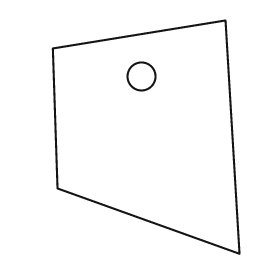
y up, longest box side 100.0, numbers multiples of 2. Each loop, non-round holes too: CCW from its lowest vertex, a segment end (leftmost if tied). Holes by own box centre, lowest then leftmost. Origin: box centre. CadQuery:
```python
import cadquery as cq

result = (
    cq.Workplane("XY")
    .moveTo(40.0, -50.0)
    .lineTo(34.0, 50.0)
    .lineTo(-40.0, 38.0)
    .lineTo(-38.0, -22.0)
    .close()
    .moveTo(-2.0, 26.0)
    .circle(6.0)
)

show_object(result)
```